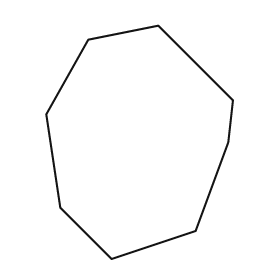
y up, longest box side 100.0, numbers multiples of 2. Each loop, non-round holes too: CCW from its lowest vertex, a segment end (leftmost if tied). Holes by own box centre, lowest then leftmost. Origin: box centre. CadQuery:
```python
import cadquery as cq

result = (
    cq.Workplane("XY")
    .moveTo(-12.0, -50.0)
    .lineTo(24.0, -38.0)
    .lineTo(38.0, 0.0)
    .lineTo(40.0, 18.0)
    .lineTo(8.0, 50.0)
    .lineTo(-22.0, 44.0)
    .lineTo(-40.0, 12.0)
    .lineTo(-34.0, -28.0)
    .close()
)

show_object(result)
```